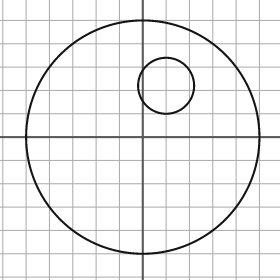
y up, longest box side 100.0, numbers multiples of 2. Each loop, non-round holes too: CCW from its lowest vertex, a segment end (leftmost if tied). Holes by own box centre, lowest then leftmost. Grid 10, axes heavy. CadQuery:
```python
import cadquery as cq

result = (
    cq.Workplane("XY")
    .moveTo(0.0, 0.0)
    .circle(50.0)
    .moveTo(10.0, 22.0)
    .circle(12.0)
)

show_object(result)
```